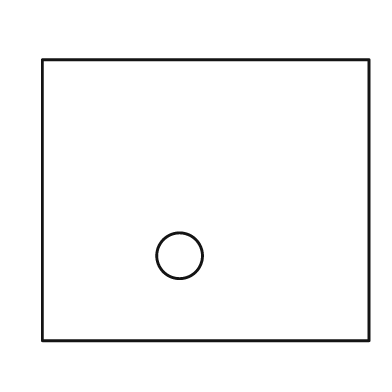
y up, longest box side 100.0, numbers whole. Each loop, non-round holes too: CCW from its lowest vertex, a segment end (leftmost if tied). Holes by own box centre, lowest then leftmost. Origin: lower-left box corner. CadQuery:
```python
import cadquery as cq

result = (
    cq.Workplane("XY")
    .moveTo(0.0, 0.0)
    .lineTo(100.0, 0.0)
    .lineTo(100.0, 86.0)
    .lineTo(0.0, 86.0)
    .close()
    .moveTo(42.0, 26.0)
    .circle(7.0)
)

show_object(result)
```